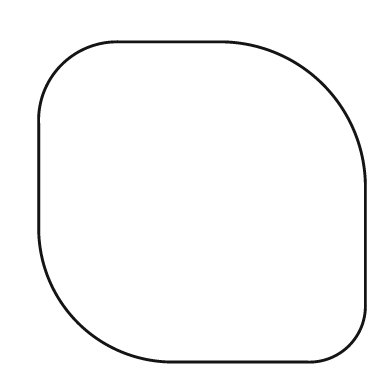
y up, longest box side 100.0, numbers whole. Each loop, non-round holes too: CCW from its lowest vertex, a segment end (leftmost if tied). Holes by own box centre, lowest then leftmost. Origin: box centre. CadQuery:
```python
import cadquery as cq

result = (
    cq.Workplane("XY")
    .moveTo(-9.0, -49.0)
    .lineTo(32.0, -49.0)
    .threePointArc((45.0, -44.0), (50.0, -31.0))
    .lineTo(50.0, 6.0)
    .threePointArc((37.0, 36.0), (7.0, 49.0))
    .lineTo(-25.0, 49.0)
    .threePointArc((-43.0, 42.0), (-50.0, 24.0))
    .lineTo(-50.0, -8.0)
    .threePointArc((-38.0, -37.0), (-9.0, -49.0))
    .close()
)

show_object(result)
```